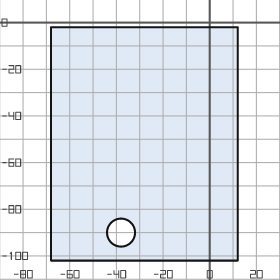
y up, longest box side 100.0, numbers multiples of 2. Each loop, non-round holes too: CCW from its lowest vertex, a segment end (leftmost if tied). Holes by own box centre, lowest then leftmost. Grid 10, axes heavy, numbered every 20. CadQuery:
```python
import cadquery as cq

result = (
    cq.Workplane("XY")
    .moveTo(-68.0, -102.0)
    .lineTo(12.0, -102.0)
    .lineTo(12.0, -2.0)
    .lineTo(-68.0, -2.0)
    .close()
    .moveTo(-38.0, -90.0)
    .circle(6.0)
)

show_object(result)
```